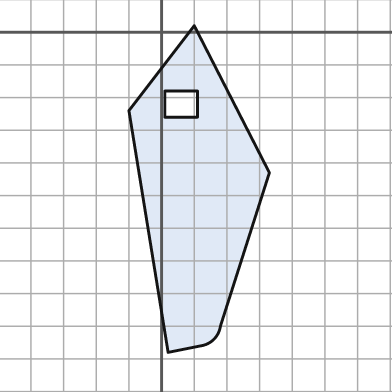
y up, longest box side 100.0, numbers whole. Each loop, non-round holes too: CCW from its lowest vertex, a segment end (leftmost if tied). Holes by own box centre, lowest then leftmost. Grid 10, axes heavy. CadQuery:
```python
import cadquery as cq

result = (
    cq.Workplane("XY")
    .moveTo(2.0, -98.0)
    .lineTo(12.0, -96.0)
    .threePointArc((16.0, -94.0), (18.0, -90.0))
    .lineTo(33.0, -43.0)
    .lineTo(10.0, 2.0)
    .lineTo(-10.0, -24.0)
    .close()
    .moveTo(1.0, -26.0)
    .lineTo(11.0, -26.0)
    .lineTo(11.0, -18.0)
    .lineTo(1.0, -18.0)
    .close()
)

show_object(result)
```